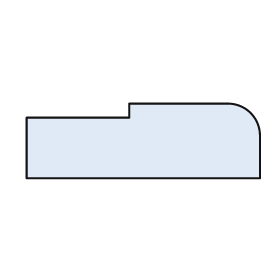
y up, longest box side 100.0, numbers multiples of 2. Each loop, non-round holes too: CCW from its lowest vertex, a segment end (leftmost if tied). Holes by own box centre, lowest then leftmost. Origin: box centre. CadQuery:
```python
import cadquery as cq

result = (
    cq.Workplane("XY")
    .moveTo(-50.0, -16.0)
    .lineTo(50.0, -16.0)
    .lineTo(50.0, 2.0)
    .threePointArc((46.0, 12.0), (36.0, 16.0))
    .lineTo(-6.0, 16.0)
    .lineTo(-6.0, 10.0)
    .lineTo(-50.0, 10.0)
    .close()
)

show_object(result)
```